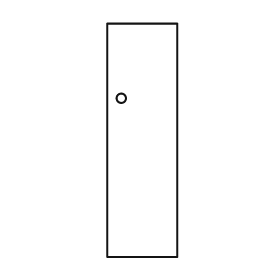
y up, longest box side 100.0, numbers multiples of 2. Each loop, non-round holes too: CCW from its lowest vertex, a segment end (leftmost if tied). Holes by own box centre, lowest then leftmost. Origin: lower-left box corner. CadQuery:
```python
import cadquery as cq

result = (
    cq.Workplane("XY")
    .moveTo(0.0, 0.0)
    .lineTo(30.0, 0.0)
    .lineTo(30.0, 100.0)
    .lineTo(0.0, 100.0)
    .close()
    .moveTo(6.0, 68.0)
    .circle(2.0)
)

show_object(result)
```